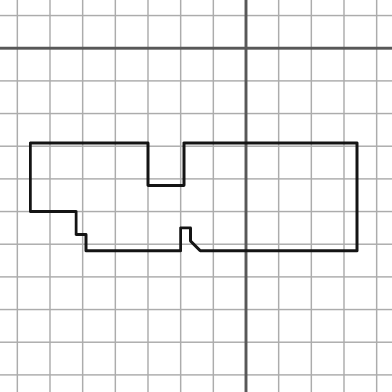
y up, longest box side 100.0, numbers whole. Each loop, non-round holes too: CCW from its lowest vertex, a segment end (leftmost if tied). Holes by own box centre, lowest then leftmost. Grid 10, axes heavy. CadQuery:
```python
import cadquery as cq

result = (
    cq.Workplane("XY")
    .moveTo(-49.0, -62.0)
    .lineTo(-20.0, -62.0)
    .lineTo(-20.0, -55.0)
    .lineTo(-17.0, -55.0)
    .lineTo(-17.0, -59.0)
    .lineTo(-14.0, -62.0)
    .lineTo(34.0, -62.0)
    .lineTo(34.0, -29.0)
    .lineTo(-19.0, -29.0)
    .lineTo(-19.0, -42.0)
    .lineTo(-30.0, -42.0)
    .lineTo(-30.0, -29.0)
    .lineTo(-66.0, -29.0)
    .lineTo(-66.0, -50.0)
    .lineTo(-52.0, -50.0)
    .lineTo(-52.0, -57.0)
    .lineTo(-49.0, -57.0)
    .close()
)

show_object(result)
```